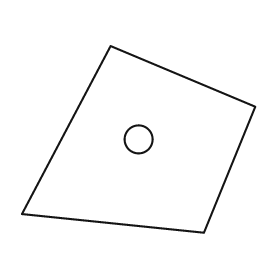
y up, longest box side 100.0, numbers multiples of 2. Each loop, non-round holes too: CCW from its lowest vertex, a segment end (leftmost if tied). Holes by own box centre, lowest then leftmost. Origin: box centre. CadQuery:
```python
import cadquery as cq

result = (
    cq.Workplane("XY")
    .moveTo(28.0, -40.0)
    .lineTo(50.0, 14.0)
    .lineTo(-12.0, 40.0)
    .lineTo(-50.0, -32.0)
    .close()
    .moveTo(0.0, 0.0)
    .circle(6.0)
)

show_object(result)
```